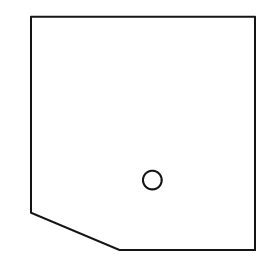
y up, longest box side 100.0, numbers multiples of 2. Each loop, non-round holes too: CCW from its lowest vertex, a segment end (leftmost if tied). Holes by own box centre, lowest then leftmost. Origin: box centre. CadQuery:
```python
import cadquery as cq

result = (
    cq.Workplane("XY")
    .moveTo(-10.0, -50.0)
    .lineTo(48.0, -50.0)
    .lineTo(48.0, 50.0)
    .lineTo(-48.0, 50.0)
    .lineTo(-48.0, -34.0)
    .close()
    .moveTo(4.0, -20.0)
    .circle(4.0)
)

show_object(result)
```